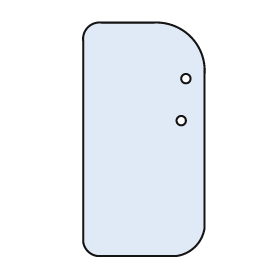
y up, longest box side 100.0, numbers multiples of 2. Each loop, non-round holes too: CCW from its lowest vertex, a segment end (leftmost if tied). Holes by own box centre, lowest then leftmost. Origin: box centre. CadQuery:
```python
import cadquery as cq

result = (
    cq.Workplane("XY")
    .moveTo(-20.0, -50.0)
    .lineTo(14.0, -50.0)
    .threePointArc((22.0, -46.0), (26.0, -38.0))
    .lineTo(26.0, 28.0)
    .threePointArc((20.0, 44.0), (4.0, 50.0))
    .lineTo(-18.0, 50.0)
    .threePointArc((-24.0, 48.0), (-26.0, 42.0))
    .lineTo(-26.0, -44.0)
    .threePointArc((-24.0, -48.0), (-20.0, -50.0))
    .close()
    .moveTo(16.0, 8.0)
    .circle(2.0)
    .moveTo(18.0, 26.0)
    .circle(2.0)
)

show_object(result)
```